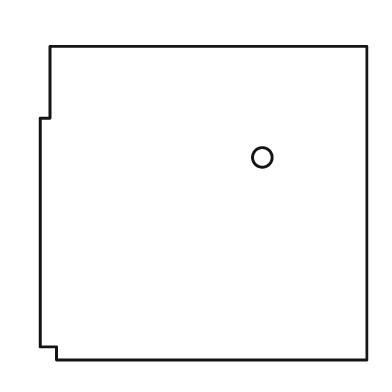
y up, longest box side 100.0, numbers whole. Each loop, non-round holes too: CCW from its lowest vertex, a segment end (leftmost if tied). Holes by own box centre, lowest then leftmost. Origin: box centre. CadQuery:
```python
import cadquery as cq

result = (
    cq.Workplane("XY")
    .moveTo(-45.0, -48.0)
    .lineTo(50.0, -48.0)
    .lineTo(50.0, 48.0)
    .lineTo(-47.0, 48.0)
    .lineTo(-47.0, 26.0)
    .lineTo(-50.0, 26.0)
    .lineTo(-50.0, -44.0)
    .lineTo(-45.0, -44.0)
    .close()
    .moveTo(18.0, 14.0)
    .circle(3.0)
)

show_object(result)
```